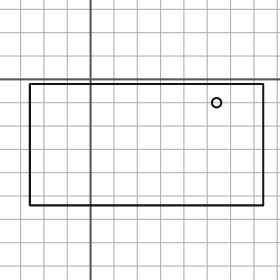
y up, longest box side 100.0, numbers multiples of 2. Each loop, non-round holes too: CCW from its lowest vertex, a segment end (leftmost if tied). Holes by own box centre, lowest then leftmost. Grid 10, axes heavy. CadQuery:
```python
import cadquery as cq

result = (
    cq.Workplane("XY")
    .moveTo(-26.0, -54.0)
    .lineTo(74.0, -54.0)
    .lineTo(74.0, -2.0)
    .lineTo(-26.0, -2.0)
    .close()
    .moveTo(54.0, -10.0)
    .circle(2.0)
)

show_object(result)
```